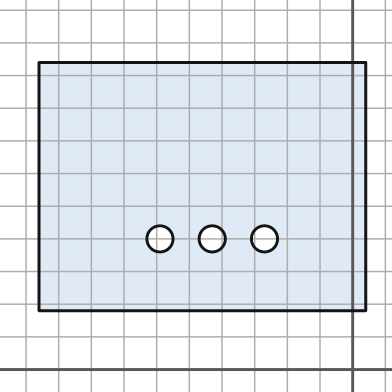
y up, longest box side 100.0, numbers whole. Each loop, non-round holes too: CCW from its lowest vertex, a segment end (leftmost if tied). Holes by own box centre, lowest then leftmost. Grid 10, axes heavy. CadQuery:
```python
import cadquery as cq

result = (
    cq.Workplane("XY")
    .moveTo(-96.0, 18.0)
    .lineTo(4.0, 18.0)
    .lineTo(4.0, 94.0)
    .lineTo(-96.0, 94.0)
    .close()
    .moveTo(-59.0, 40.0)
    .circle(4.0)
    .moveTo(-43.0, 40.0)
    .circle(4.0)
    .moveTo(-27.0, 40.0)
    .circle(4.0)
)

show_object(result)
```